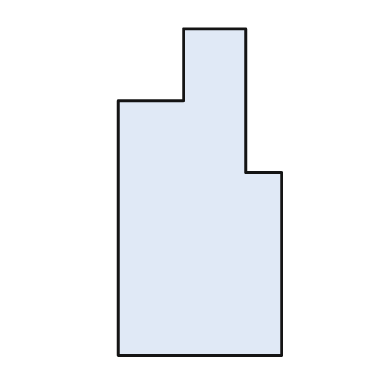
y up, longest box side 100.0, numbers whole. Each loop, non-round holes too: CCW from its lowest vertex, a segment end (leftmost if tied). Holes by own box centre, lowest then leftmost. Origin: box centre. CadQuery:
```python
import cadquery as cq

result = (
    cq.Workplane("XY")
    .moveTo(-25.0, -50.0)
    .lineTo(25.0, -50.0)
    .lineTo(25.0, 6.0)
    .lineTo(14.0, 6.0)
    .lineTo(14.0, 50.0)
    .lineTo(-5.0, 50.0)
    .lineTo(-5.0, 28.0)
    .lineTo(-25.0, 28.0)
    .close()
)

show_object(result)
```